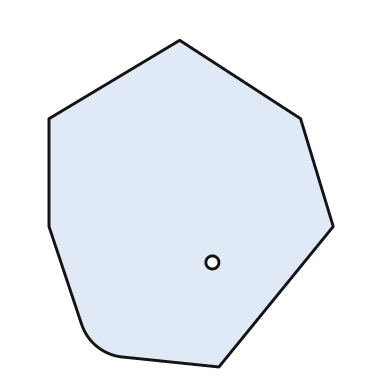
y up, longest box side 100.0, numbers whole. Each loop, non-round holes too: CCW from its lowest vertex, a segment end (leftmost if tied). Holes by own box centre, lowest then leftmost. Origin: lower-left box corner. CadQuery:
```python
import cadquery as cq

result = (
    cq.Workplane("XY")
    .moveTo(52.0, 0.0)
    .lineTo(87.0, 43.0)
    .lineTo(77.0, 76.0)
    .lineTo(40.0, 100.0)
    .lineTo(0.0, 76.0)
    .lineTo(0.0, 43.0)
    .lineTo(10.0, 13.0)
    .threePointArc((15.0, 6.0), (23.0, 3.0))
    .close()
    .moveTo(50.0, 32.0)
    .circle(2.0)
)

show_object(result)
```